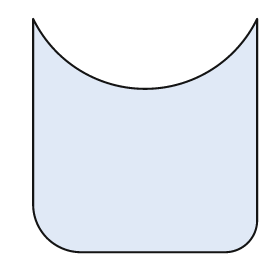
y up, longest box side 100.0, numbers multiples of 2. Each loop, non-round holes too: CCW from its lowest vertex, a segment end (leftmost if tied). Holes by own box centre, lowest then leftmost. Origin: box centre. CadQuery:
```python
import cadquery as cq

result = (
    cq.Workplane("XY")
    .moveTo(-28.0, -50.0)
    .lineTo(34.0, -50.0)
    .threePointArc((44.0, -46.0), (48.0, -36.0))
    .lineTo(48.0, 50.0)
    .threePointArc((0.0, 20.0), (-48.0, 50.0))
    .lineTo(-48.0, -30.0)
    .threePointArc((-42.0, -44.0), (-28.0, -50.0))
    .close()
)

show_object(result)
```